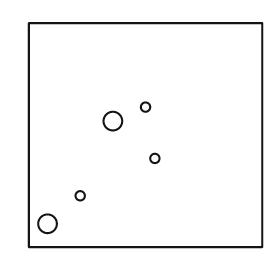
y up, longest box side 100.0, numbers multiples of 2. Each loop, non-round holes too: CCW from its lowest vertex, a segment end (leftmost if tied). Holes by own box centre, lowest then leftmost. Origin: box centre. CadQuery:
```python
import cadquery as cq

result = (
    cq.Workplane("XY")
    .moveTo(-50.0, -48.0)
    .lineTo(50.0, -48.0)
    .lineTo(50.0, 48.0)
    .lineTo(-50.0, 48.0)
    .close()
    .moveTo(-42.0, -38.0)
    .circle(4.0)
    .moveTo(-28.0, -26.0)
    .circle(2.0)
    .moveTo(4.0, -10.0)
    .circle(2.0)
    .moveTo(-14.0, 6.0)
    .circle(4.0)
    .moveTo(0.0, 12.0)
    .circle(2.0)
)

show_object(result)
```